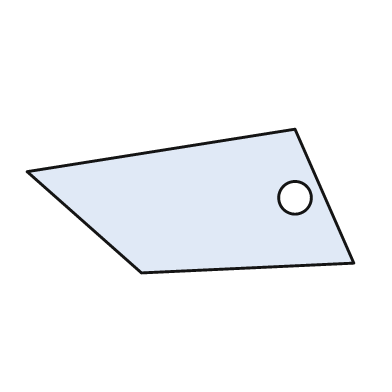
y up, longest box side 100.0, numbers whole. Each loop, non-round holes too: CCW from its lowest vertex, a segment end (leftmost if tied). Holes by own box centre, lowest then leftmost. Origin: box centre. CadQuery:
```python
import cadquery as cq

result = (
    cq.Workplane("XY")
    .moveTo(-15.0, -22.0)
    .lineTo(50.0, -19.0)
    .lineTo(32.0, 22.0)
    .lineTo(-50.0, 9.0)
    .close()
    .moveTo(32.0, 1.0)
    .circle(5.0)
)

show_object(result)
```